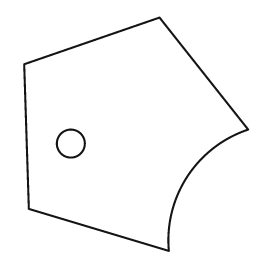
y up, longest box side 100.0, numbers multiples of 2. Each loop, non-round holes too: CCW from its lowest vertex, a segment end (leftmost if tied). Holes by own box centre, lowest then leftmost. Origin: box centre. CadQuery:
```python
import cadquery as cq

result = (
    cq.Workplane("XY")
    .moveTo(14.0, -50.0)
    .threePointArc((22.0, -18.0), (48.0, 2.0))
    .lineTo(10.0, 50.0)
    .lineTo(-48.0, 30.0)
    .lineTo(-46.0, -32.0)
    .close()
    .moveTo(-28.0, -4.0)
    .circle(6.0)
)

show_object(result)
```